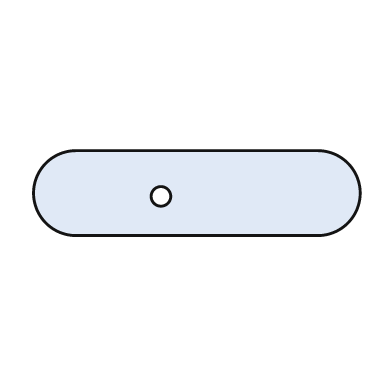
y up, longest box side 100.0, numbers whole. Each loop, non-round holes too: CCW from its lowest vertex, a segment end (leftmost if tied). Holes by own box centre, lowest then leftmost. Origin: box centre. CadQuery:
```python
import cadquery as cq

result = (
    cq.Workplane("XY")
    .moveTo(-37.0, -13.0)
    .lineTo(37.0, -13.0)
    .threePointArc((50.0, 0.0), (37.0, 13.0))
    .lineTo(-37.0, 13.0)
    .threePointArc((-50.0, 0.0), (-37.0, -13.0))
    .close()
    .moveTo(-11.0, -1.0)
    .circle(3.0)
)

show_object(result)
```